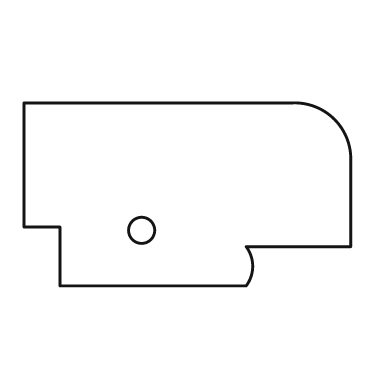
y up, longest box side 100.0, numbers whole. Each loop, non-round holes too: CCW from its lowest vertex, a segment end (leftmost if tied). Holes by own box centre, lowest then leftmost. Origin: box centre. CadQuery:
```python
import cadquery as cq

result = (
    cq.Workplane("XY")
    .moveTo(-39.0, -28.0)
    .lineTo(18.0, -28.0)
    .threePointArc((20.0, -22.0), (18.0, -16.0))
    .lineTo(50.0, -16.0)
    .lineTo(50.0, 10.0)
    .threePointArc((45.0, 23.0), (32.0, 28.0))
    .lineTo(-50.0, 28.0)
    .lineTo(-50.0, -10.0)
    .lineTo(-39.0, -10.0)
    .close()
    .moveTo(-14.0, -11.0)
    .circle(4.0)
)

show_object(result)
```